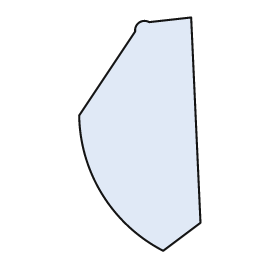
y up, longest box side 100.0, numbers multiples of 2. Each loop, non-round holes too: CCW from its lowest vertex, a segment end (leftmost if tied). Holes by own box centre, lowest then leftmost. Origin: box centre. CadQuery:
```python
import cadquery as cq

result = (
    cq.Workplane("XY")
    .moveTo(10.0, -50.0)
    .lineTo(26.0, -38.0)
    .lineTo(22.0, 50.0)
    .lineTo(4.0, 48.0)
    .threePointArc((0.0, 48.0), (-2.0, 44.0))
    .lineTo(-26.0, 8.0)
    .threePointArc((-16.0, -26.0), (10.0, -50.0))
    .close()
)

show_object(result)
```